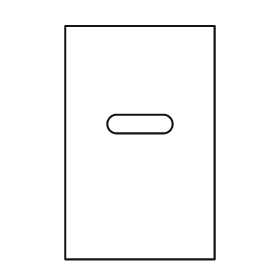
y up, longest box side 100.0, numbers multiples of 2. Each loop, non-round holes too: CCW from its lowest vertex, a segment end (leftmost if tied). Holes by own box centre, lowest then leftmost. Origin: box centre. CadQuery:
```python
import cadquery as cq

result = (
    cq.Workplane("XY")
    .moveTo(-32.0, -50.0)
    .lineTo(32.0, -50.0)
    .lineTo(32.0, 50.0)
    .lineTo(-32.0, 50.0)
    .close()
    .moveTo(-10.0, 4.0)
    .lineTo(10.0, 4.0)
    .threePointArc((14.0, 8.0), (10.0, 12.0))
    .lineTo(-10.0, 12.0)
    .threePointArc((-14.0, 8.0), (-10.0, 4.0))
    .close()
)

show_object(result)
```